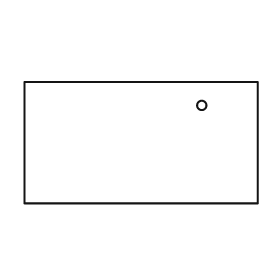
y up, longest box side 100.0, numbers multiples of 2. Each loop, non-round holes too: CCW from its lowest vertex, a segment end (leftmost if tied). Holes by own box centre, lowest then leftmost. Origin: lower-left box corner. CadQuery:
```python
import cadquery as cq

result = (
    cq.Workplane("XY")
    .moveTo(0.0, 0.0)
    .lineTo(100.0, 0.0)
    .lineTo(100.0, 52.0)
    .lineTo(0.0, 52.0)
    .close()
    .moveTo(76.0, 42.0)
    .circle(2.0)
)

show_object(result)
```